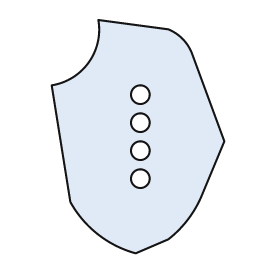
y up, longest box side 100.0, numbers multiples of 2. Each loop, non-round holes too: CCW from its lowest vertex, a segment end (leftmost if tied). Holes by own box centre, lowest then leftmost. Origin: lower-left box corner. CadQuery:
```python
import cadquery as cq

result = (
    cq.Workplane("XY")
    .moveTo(36.0, 0.0)
    .lineTo(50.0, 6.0)
    .threePointArc((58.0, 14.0), (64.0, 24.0))
    .lineTo(74.0, 48.0)
    .lineTo(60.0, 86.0)
    .threePointArc((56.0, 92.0), (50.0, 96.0))
    .lineTo(20.0, 100.0)
    .threePointArc((16.0, 82.0), (0.0, 72.0))
    .lineTo(8.0, 22.0)
    .threePointArc((20.0, 8.0), (36.0, 0.0))
    .close()
    .moveTo(38.0, 32.0)
    .circle(4.0)
    .moveTo(38.0, 44.0)
    .circle(4.0)
    .moveTo(38.0, 56.0)
    .circle(4.0)
    .moveTo(38.0, 68.0)
    .circle(4.0)
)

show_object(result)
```